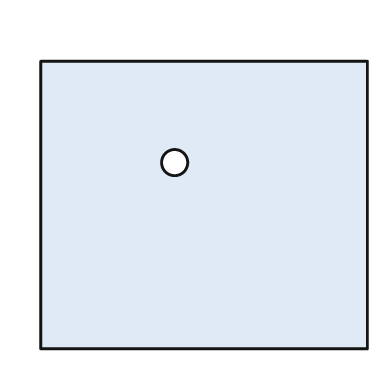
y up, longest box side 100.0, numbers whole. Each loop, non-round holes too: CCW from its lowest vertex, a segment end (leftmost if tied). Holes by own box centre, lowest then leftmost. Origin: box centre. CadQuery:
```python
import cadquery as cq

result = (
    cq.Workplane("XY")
    .moveTo(-50.0, -44.0)
    .lineTo(50.0, -44.0)
    .lineTo(50.0, 44.0)
    .lineTo(-50.0, 44.0)
    .close()
    .moveTo(-9.0, 13.0)
    .circle(4.0)
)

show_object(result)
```